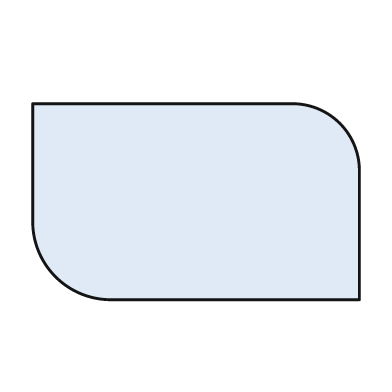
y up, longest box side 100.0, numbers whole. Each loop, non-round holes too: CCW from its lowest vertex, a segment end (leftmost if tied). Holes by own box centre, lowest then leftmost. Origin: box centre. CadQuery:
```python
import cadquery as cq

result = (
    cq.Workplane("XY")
    .moveTo(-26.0, -30.0)
    .lineTo(50.0, -30.0)
    .lineTo(50.0, 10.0)
    .threePointArc((44.0, 24.0), (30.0, 30.0))
    .lineTo(-50.0, 30.0)
    .lineTo(-50.0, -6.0)
    .threePointArc((-43.0, -23.0), (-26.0, -30.0))
    .close()
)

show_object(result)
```